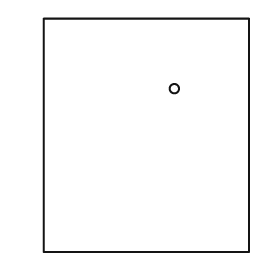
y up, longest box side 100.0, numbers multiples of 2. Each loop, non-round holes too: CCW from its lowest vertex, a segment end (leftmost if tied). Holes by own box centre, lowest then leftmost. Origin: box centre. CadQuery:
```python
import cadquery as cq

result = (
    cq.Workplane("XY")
    .moveTo(-44.0, -50.0)
    .lineTo(44.0, -50.0)
    .lineTo(44.0, 50.0)
    .lineTo(-44.0, 50.0)
    .close()
    .moveTo(12.0, 20.0)
    .circle(2.0)
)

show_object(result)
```